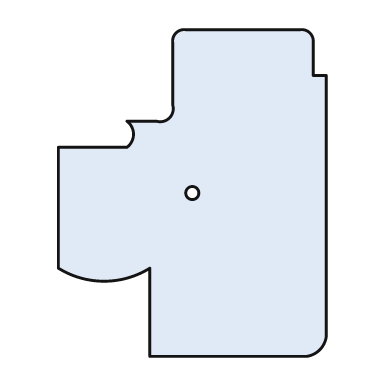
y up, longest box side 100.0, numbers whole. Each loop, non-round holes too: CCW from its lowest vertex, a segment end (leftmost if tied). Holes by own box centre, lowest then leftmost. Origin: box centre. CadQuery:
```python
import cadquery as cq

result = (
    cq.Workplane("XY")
    .moveTo(-13.0, -50.0)
    .lineTo(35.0, -50.0)
    .threePointArc((39.0, -48.0), (41.0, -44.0))
    .lineTo(41.0, 36.0)
    .lineTo(37.0, 36.0)
    .lineTo(37.0, 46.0)
    .threePointArc((36.0, 49.0), (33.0, 50.0))
    .lineTo(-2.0, 50.0)
    .threePointArc((-5.0, 49.0), (-6.0, 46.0))
    .lineTo(-6.0, 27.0)
    .threePointArc((-7.0, 23.0), (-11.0, 22.0))
    .lineTo(-20.0, 22.0)
    .threePointArc((-18.0, 18.0), (-20.0, 14.0))
    .lineTo(-41.0, 14.0)
    .lineTo(-41.0, -23.0)
    .threePointArc((-27.0, -27.0), (-13.0, -23.0))
    .close()
    .moveTo(0.0, 0.0)
    .circle(2.0)
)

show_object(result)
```